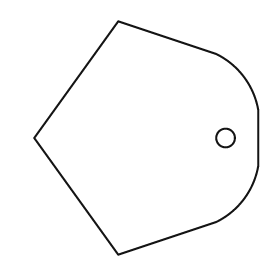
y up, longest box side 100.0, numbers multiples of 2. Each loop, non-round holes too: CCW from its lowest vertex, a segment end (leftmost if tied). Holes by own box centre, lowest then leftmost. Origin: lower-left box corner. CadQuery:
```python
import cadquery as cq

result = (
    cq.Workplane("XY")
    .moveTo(36.0, 0.0)
    .lineTo(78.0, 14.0)
    .threePointArc((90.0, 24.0), (96.0, 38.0))
    .lineTo(96.0, 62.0)
    .threePointArc((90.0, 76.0), (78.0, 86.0))
    .lineTo(36.0, 100.0)
    .lineTo(0.0, 50.0)
    .close()
    .moveTo(82.0, 50.0)
    .circle(4.0)
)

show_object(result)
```